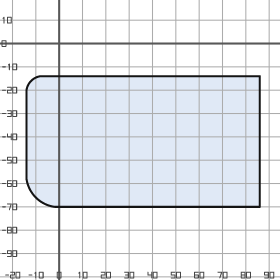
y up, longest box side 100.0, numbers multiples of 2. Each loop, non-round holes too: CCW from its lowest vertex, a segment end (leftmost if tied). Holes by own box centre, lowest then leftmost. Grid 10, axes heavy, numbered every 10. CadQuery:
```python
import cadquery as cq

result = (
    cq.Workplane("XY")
    .moveTo(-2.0, -70.0)
    .lineTo(86.0, -70.0)
    .lineTo(86.0, -14.0)
    .lineTo(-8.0, -14.0)
    .threePointArc((-12.0, -16.0), (-14.0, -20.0))
    .lineTo(-14.0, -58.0)
    .threePointArc((-10.0, -66.0), (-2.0, -70.0))
    .close()
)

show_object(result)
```